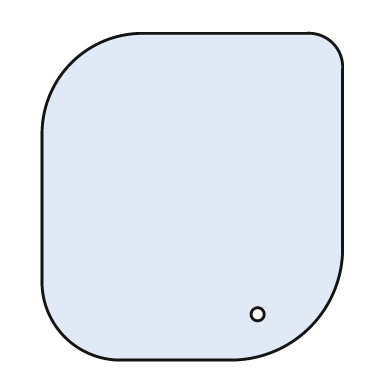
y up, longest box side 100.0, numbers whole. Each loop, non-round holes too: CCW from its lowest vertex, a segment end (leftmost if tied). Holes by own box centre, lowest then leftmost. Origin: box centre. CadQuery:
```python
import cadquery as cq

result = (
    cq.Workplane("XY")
    .moveTo(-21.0, -50.0)
    .lineTo(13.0, -50.0)
    .threePointArc((36.0, -40.0), (46.0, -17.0))
    .lineTo(46.0, 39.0)
    .threePointArc((43.0, 47.0), (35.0, 50.0))
    .lineTo(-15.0, 50.0)
    .threePointArc((-37.0, 41.0), (-46.0, 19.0))
    .lineTo(-46.0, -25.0)
    .threePointArc((-39.0, -43.0), (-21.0, -50.0))
    .close()
    .moveTo(20.0, -36.0)
    .circle(2.0)
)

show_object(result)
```